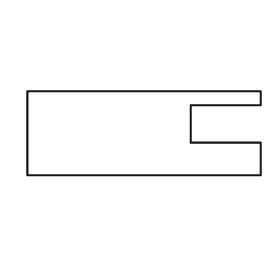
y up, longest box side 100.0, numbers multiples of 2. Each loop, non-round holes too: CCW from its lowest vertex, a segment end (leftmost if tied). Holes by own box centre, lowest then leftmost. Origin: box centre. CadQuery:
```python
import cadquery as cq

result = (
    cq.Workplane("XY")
    .moveTo(-50.0, -18.0)
    .lineTo(50.0, -18.0)
    .lineTo(50.0, -4.0)
    .lineTo(20.0, -4.0)
    .lineTo(20.0, 12.0)
    .lineTo(50.0, 12.0)
    .lineTo(50.0, 18.0)
    .lineTo(-50.0, 18.0)
    .close()
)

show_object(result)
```